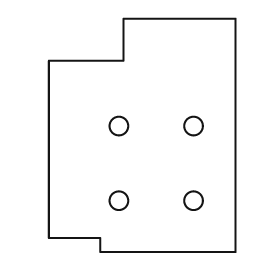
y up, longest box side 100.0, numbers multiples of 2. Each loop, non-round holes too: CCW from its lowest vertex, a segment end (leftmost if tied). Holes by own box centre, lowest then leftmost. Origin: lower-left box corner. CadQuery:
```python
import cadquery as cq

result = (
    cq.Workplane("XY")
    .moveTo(22.0, 0.0)
    .lineTo(80.0, 0.0)
    .lineTo(80.0, 100.0)
    .lineTo(32.0, 100.0)
    .lineTo(32.0, 82.0)
    .lineTo(0.0, 82.0)
    .lineTo(0.0, 6.0)
    .lineTo(22.0, 6.0)
    .close()
    .moveTo(30.0, 22.0)
    .circle(4.0)
    .moveTo(62.0, 22.0)
    .circle(4.0)
    .moveTo(30.0, 54.0)
    .circle(4.0)
    .moveTo(62.0, 54.0)
    .circle(4.0)
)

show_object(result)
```